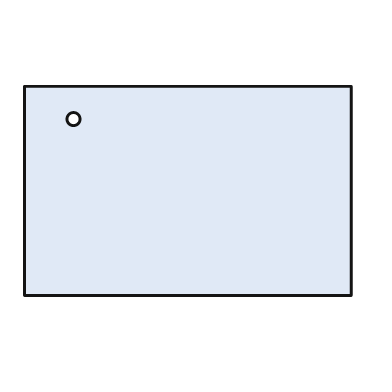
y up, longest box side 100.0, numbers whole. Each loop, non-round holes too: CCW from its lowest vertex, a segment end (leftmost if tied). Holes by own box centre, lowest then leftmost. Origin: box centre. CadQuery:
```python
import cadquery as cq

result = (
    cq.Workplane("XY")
    .moveTo(-50.0, -32.0)
    .lineTo(50.0, -32.0)
    .lineTo(50.0, 32.0)
    .lineTo(-50.0, 32.0)
    .close()
    .moveTo(-35.0, 22.0)
    .circle(2.0)
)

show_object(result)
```